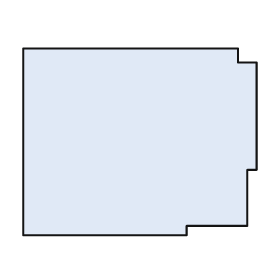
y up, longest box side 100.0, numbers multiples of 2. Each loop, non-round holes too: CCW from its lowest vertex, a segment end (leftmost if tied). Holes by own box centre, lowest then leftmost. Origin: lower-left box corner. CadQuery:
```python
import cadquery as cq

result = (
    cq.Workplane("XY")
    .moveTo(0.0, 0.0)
    .lineTo(70.0, 0.0)
    .lineTo(70.0, 4.0)
    .lineTo(96.0, 4.0)
    .lineTo(96.0, 28.0)
    .lineTo(100.0, 28.0)
    .lineTo(100.0, 74.0)
    .lineTo(92.0, 74.0)
    .lineTo(92.0, 80.0)
    .lineTo(0.0, 80.0)
    .close()
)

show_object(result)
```